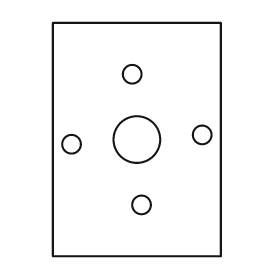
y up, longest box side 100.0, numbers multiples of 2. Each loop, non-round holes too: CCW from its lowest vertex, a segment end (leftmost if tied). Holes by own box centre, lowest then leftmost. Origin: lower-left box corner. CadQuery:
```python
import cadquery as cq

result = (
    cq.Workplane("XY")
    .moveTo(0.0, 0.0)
    .lineTo(72.0, 0.0)
    .lineTo(72.0, 100.0)
    .lineTo(0.0, 100.0)
    .close()
    .moveTo(38.0, 22.0)
    .circle(4.0)
    .moveTo(8.0, 48.0)
    .circle(4.0)
    .moveTo(36.0, 50.0)
    .circle(10.0)
    .moveTo(64.0, 52.0)
    .circle(4.0)
    .moveTo(34.0, 78.0)
    .circle(4.0)
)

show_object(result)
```